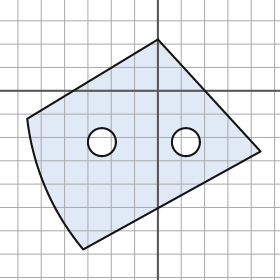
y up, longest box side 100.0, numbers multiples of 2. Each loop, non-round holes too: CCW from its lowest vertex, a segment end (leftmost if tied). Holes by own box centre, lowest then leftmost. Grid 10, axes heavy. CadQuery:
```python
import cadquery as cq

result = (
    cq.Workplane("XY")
    .moveTo(-32.0, -68.0)
    .lineTo(44.0, -26.0)
    .lineTo(0.0, 22.0)
    .lineTo(-56.0, -12.0)
    .threePointArc((-48.0, -42.0), (-32.0, -68.0))
    .close()
    .moveTo(-24.0, -22.0)
    .circle(6.0)
    .moveTo(12.0, -22.0)
    .circle(6.0)
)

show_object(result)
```